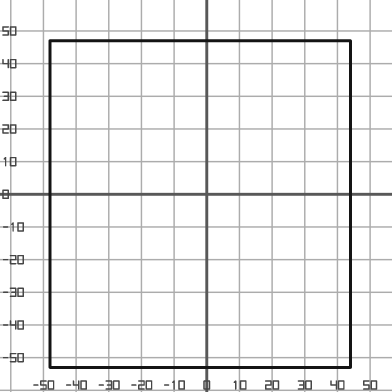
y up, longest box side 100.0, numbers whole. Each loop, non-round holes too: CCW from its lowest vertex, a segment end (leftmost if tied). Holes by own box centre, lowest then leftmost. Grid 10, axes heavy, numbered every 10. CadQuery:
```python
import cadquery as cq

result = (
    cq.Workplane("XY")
    .moveTo(-48.0, -53.0)
    .lineTo(44.0, -53.0)
    .lineTo(44.0, 47.0)
    .lineTo(-48.0, 47.0)
    .close()
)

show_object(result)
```